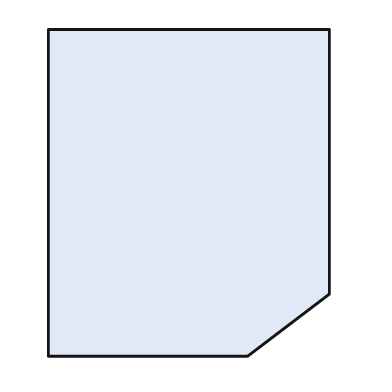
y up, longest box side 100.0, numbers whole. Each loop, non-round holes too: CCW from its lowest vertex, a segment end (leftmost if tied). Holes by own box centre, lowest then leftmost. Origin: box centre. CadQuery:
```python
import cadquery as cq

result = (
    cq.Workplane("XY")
    .moveTo(-43.0, -50.0)
    .lineTo(18.0, -50.0)
    .lineTo(43.0, -31.0)
    .lineTo(43.0, 50.0)
    .lineTo(-43.0, 50.0)
    .close()
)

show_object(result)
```